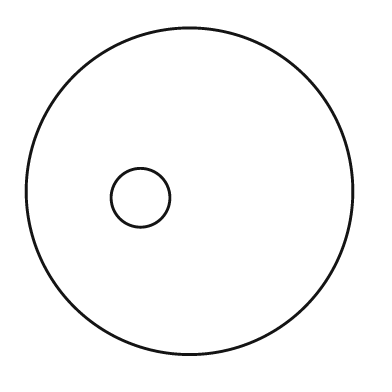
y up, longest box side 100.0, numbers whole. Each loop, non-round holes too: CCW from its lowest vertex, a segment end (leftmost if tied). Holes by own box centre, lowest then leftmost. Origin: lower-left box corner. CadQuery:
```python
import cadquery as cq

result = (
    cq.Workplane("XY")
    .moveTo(50.0, 50.0)
    .circle(50.0)
    .moveTo(35.0, 48.0)
    .circle(9.0)
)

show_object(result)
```